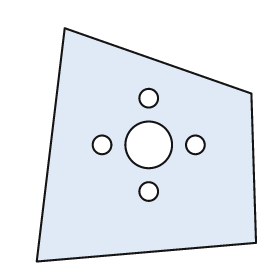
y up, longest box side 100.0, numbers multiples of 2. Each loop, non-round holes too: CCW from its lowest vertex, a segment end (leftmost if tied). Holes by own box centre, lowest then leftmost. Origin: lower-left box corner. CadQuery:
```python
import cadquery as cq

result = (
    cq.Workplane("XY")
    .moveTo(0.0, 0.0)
    .lineTo(94.0, 8.0)
    .lineTo(92.0, 72.0)
    .lineTo(12.0, 100.0)
    .close()
    .moveTo(48.0, 30.0)
    .circle(4.0)
    .moveTo(28.0, 50.0)
    .circle(4.0)
    .moveTo(48.0, 50.0)
    .circle(10.0)
    .moveTo(68.0, 50.0)
    .circle(4.0)
    .moveTo(48.0, 70.0)
    .circle(4.0)
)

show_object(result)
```